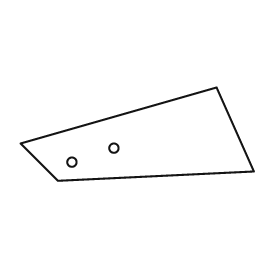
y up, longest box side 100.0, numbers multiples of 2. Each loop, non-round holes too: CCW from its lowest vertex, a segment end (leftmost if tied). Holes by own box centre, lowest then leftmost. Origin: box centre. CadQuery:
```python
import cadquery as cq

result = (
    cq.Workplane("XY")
    .moveTo(-34.0, -20.0)
    .lineTo(50.0, -16.0)
    .lineTo(34.0, 20.0)
    .lineTo(-50.0, -4.0)
    .close()
    .moveTo(-28.0, -12.0)
    .circle(2.0)
    .moveTo(-10.0, -6.0)
    .circle(2.0)
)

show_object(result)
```